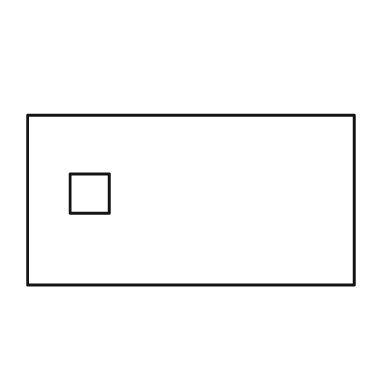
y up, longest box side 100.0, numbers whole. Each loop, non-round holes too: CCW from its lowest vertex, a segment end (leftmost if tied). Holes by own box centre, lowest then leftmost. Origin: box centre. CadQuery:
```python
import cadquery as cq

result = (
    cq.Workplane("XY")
    .moveTo(-50.0, -26.0)
    .lineTo(50.0, -26.0)
    .lineTo(50.0, 26.0)
    .lineTo(-50.0, 26.0)
    .close()
    .moveTo(-37.0, -4.0)
    .lineTo(-25.0, -4.0)
    .lineTo(-25.0, 8.0)
    .lineTo(-37.0, 8.0)
    .close()
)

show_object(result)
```